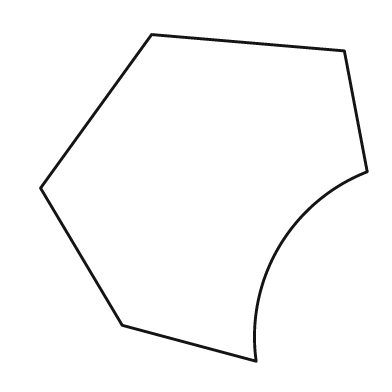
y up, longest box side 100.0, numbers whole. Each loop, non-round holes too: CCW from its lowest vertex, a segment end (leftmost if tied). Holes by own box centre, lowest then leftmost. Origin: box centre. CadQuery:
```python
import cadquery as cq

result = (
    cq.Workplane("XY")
    .moveTo(16.0, -50.0)
    .threePointArc((23.0, -15.0), (50.0, 8.0))
    .lineTo(43.0, 45.0)
    .lineTo(-16.0, 50.0)
    .lineTo(-50.0, 3.0)
    .lineTo(-25.0, -39.0)
    .close()
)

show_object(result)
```